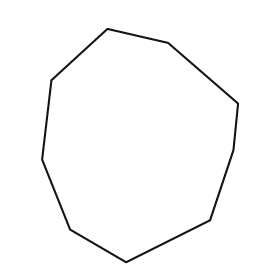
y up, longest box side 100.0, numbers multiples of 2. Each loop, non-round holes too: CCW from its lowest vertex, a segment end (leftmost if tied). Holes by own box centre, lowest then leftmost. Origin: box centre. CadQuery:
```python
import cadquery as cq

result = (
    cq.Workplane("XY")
    .moveTo(-6.0, -50.0)
    .lineTo(30.0, -32.0)
    .lineTo(40.0, -2.0)
    .lineTo(42.0, 18.0)
    .lineTo(12.0, 44.0)
    .lineTo(-14.0, 50.0)
    .lineTo(-38.0, 28.0)
    .lineTo(-42.0, -6.0)
    .lineTo(-30.0, -36.0)
    .close()
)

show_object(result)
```